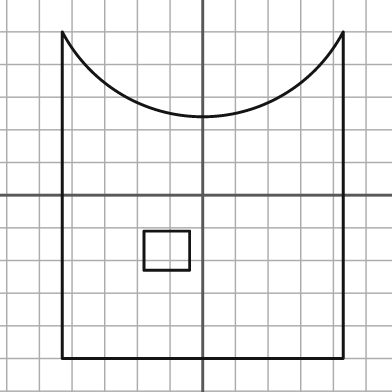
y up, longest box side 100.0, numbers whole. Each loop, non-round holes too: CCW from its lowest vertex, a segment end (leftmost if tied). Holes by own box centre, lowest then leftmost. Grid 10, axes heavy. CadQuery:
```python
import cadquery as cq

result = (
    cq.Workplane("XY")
    .moveTo(-43.0, -50.0)
    .lineTo(43.0, -50.0)
    .lineTo(43.0, 50.0)
    .threePointArc((0.0, 24.0), (-43.0, 50.0))
    .close()
    .moveTo(-18.0, -23.0)
    .lineTo(-4.0, -23.0)
    .lineTo(-4.0, -11.0)
    .lineTo(-18.0, -11.0)
    .close()
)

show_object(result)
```